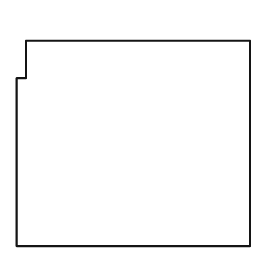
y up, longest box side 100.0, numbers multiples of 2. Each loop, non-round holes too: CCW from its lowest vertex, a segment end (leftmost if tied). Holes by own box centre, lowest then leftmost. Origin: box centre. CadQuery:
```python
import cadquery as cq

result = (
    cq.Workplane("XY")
    .moveTo(-50.0, -44.0)
    .lineTo(50.0, -44.0)
    .lineTo(50.0, 44.0)
    .lineTo(-46.0, 44.0)
    .lineTo(-46.0, 28.0)
    .lineTo(-50.0, 28.0)
    .close()
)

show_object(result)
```